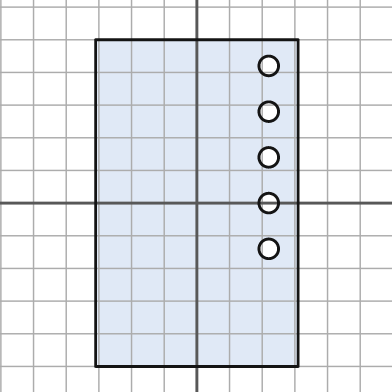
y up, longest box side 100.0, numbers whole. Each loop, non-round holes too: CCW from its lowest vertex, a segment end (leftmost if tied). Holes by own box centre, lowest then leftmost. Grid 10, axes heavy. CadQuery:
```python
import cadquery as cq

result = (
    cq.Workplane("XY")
    .moveTo(-31.0, -50.0)
    .lineTo(31.0, -50.0)
    .lineTo(31.0, 50.0)
    .lineTo(-31.0, 50.0)
    .close()
    .moveTo(22.0, -14.0)
    .circle(3.0)
    .moveTo(22.0, 0.0)
    .circle(3.0)
    .moveTo(22.0, 14.0)
    .circle(3.0)
    .moveTo(22.0, 28.0)
    .circle(3.0)
    .moveTo(22.0, 42.0)
    .circle(3.0)
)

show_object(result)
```